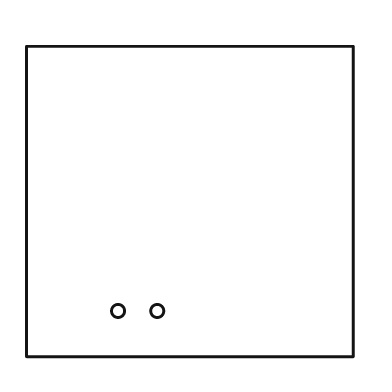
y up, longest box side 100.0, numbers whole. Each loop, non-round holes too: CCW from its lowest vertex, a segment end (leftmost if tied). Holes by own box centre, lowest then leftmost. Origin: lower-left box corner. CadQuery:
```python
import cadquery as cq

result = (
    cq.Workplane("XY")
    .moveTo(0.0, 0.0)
    .lineTo(100.0, 0.0)
    .lineTo(100.0, 95.0)
    .lineTo(0.0, 95.0)
    .close()
    .moveTo(28.0, 14.0)
    .circle(2.0)
    .moveTo(40.0, 14.0)
    .circle(2.0)
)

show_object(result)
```